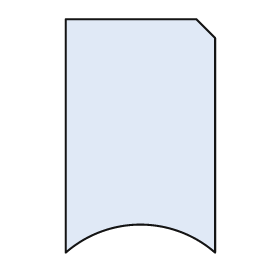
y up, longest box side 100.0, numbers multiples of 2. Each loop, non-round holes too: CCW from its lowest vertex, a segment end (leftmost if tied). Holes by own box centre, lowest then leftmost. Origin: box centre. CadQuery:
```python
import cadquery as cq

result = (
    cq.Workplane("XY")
    .moveTo(-32.0, -50.0)
    .threePointArc((0.0, -38.0), (32.0, -50.0))
    .lineTo(32.0, 42.0)
    .lineTo(24.0, 50.0)
    .lineTo(-32.0, 50.0)
    .close()
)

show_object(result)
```